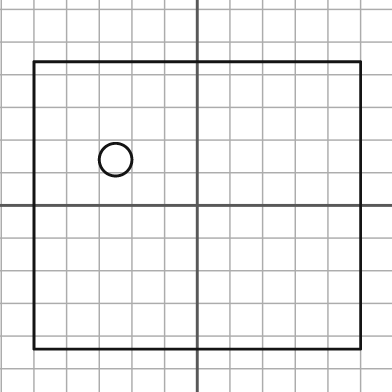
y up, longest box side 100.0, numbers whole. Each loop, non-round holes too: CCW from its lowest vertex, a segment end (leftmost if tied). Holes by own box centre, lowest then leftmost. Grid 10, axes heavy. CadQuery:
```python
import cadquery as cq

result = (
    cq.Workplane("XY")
    .moveTo(-50.0, -44.0)
    .lineTo(50.0, -44.0)
    .lineTo(50.0, 44.0)
    .lineTo(-50.0, 44.0)
    .close()
    .moveTo(-25.0, 14.0)
    .circle(5.0)
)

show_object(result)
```